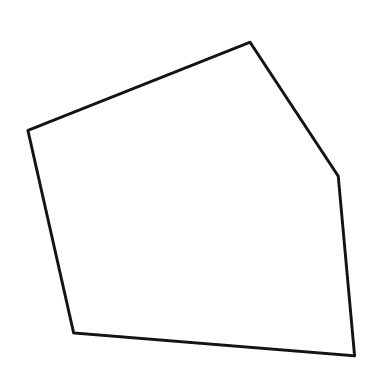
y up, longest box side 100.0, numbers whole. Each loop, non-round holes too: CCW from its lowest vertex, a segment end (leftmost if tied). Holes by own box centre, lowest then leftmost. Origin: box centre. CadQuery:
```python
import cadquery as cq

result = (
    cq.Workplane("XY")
    .moveTo(50.0, -48.0)
    .lineTo(45.0, 7.0)
    .lineTo(18.0, 48.0)
    .lineTo(-50.0, 21.0)
    .lineTo(-36.0, -41.0)
    .close()
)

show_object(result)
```